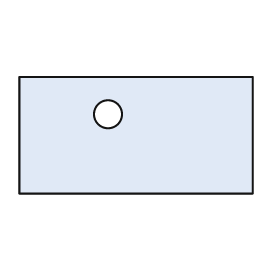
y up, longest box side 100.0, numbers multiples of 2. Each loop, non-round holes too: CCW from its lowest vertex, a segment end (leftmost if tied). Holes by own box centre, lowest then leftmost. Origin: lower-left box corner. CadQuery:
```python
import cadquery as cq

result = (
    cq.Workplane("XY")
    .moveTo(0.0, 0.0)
    .lineTo(100.0, 0.0)
    .lineTo(100.0, 50.0)
    .lineTo(0.0, 50.0)
    .close()
    .moveTo(38.0, 34.0)
    .circle(6.0)
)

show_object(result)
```